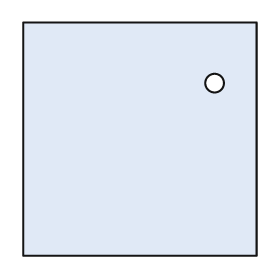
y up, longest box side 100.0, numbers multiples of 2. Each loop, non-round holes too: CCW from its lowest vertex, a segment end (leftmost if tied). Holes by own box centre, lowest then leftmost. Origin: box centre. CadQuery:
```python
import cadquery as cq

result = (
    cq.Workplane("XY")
    .moveTo(-50.0, -50.0)
    .lineTo(50.0, -50.0)
    .lineTo(50.0, 50.0)
    .lineTo(-50.0, 50.0)
    .close()
    .moveTo(32.0, 24.0)
    .circle(4.0)
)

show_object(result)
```